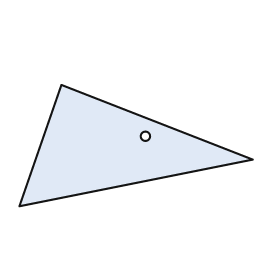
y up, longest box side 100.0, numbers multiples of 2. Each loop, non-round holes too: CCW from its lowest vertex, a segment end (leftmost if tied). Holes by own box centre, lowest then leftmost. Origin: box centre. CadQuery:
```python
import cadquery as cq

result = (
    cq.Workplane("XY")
    .moveTo(-50.0, -26.0)
    .lineTo(50.0, -6.0)
    .lineTo(-32.0, 26.0)
    .close()
    .moveTo(4.0, 4.0)
    .circle(2.0)
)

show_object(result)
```